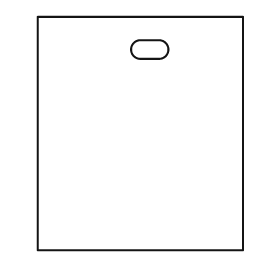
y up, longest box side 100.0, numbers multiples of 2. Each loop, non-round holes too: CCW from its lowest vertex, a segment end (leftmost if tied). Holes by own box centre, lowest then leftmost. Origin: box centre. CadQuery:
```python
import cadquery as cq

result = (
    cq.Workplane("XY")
    .moveTo(-44.0, -50.0)
    .lineTo(44.0, -50.0)
    .lineTo(44.0, 50.0)
    .lineTo(-44.0, 50.0)
    .close()
    .moveTo(0.0, 32.0)
    .lineTo(8.0, 32.0)
    .threePointArc((12.0, 36.0), (8.0, 40.0))
    .lineTo(0.0, 40.0)
    .threePointArc((-4.0, 36.0), (0.0, 32.0))
    .close()
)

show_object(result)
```